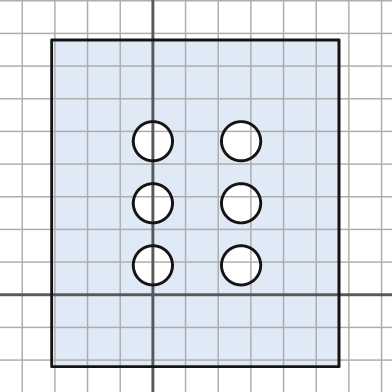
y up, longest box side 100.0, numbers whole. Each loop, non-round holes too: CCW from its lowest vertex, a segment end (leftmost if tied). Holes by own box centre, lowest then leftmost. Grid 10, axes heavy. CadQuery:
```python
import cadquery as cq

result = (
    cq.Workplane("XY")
    .moveTo(-31.0, -22.0)
    .lineTo(57.0, -22.0)
    .lineTo(57.0, 78.0)
    .lineTo(-31.0, 78.0)
    .close()
    .moveTo(0.0, 9.0)
    .circle(6.0)
    .moveTo(27.0, 9.0)
    .circle(6.0)
    .moveTo(0.0, 28.0)
    .circle(6.0)
    .moveTo(27.0, 28.0)
    .circle(6.0)
    .moveTo(0.0, 47.0)
    .circle(6.0)
    .moveTo(27.0, 47.0)
    .circle(6.0)
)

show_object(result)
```